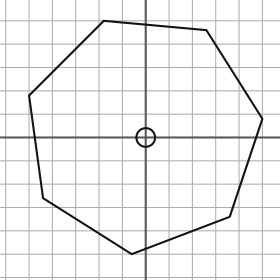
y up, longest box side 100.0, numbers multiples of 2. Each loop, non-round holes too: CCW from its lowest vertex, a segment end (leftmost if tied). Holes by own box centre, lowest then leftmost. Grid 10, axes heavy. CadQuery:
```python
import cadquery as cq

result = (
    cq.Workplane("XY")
    .moveTo(-6.0, -50.0)
    .lineTo(36.0, -34.0)
    .lineTo(50.0, 8.0)
    .lineTo(26.0, 46.0)
    .lineTo(-18.0, 50.0)
    .lineTo(-50.0, 18.0)
    .lineTo(-44.0, -26.0)
    .close()
    .moveTo(0.0, 0.0)
    .circle(4.0)
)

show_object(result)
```